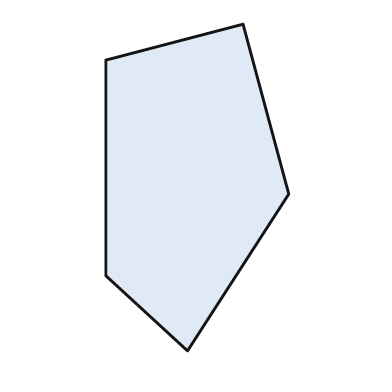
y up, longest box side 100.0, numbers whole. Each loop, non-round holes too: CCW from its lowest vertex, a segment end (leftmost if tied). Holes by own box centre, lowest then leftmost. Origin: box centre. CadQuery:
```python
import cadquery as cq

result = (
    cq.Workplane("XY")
    .moveTo(-3.0, -50.0)
    .lineTo(28.0, -2.0)
    .lineTo(14.0, 50.0)
    .lineTo(-28.0, 39.0)
    .lineTo(-28.0, -27.0)
    .close()
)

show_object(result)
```